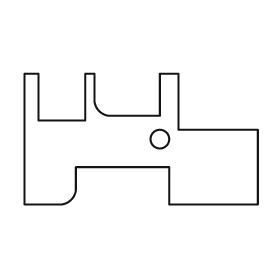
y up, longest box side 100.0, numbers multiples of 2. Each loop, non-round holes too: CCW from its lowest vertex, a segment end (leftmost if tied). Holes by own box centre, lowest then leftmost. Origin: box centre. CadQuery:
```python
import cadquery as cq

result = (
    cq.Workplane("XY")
    .moveTo(-50.0, -28.0)
    .lineTo(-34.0, -28.0)
    .threePointArc((-30.0, -26.0), (-28.0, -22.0))
    .lineTo(-28.0, -12.0)
    .lineTo(12.0, -12.0)
    .lineTo(12.0, -28.0)
    .lineTo(50.0, -28.0)
    .lineTo(50.0, 4.0)
    .lineTo(16.0, 4.0)
    .lineTo(16.0, 28.0)
    .lineTo(8.0, 28.0)
    .lineTo(8.0, 10.0)
    .lineTo(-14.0, 10.0)
    .threePointArc((-18.0, 12.0), (-20.0, 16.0))
    .lineTo(-20.0, 28.0)
    .lineTo(-24.0, 28.0)
    .lineTo(-24.0, 8.0)
    .lineTo(-44.0, 8.0)
    .lineTo(-44.0, 28.0)
    .lineTo(-50.0, 28.0)
    .close()
    .moveTo(8.0, 0.0)
    .circle(4.0)
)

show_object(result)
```